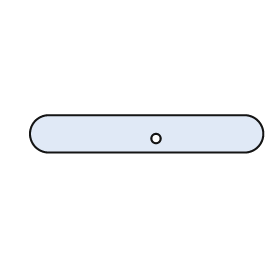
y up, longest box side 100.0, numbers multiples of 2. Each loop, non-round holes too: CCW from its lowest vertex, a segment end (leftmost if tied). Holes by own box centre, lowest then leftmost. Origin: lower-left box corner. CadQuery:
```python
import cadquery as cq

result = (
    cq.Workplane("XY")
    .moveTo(8.0, 0.0)
    .lineTo(92.0, 0.0)
    .threePointArc((100.0, 8.0), (92.0, 16.0))
    .lineTo(8.0, 16.0)
    .threePointArc((0.0, 8.0), (8.0, 0.0))
    .close()
    .moveTo(54.0, 6.0)
    .circle(2.0)
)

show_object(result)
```